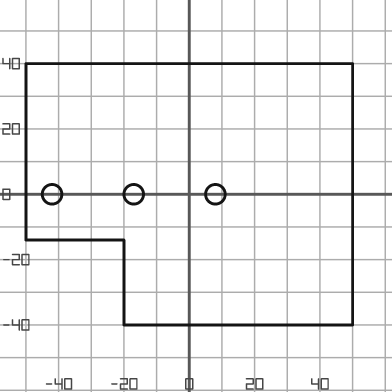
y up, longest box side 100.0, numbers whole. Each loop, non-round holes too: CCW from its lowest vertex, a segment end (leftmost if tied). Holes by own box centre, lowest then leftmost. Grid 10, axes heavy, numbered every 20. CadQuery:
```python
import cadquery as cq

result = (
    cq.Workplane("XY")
    .moveTo(-20.0, -40.0)
    .lineTo(50.0, -40.0)
    .lineTo(50.0, 40.0)
    .lineTo(-50.0, 40.0)
    .lineTo(-50.0, -14.0)
    .lineTo(-20.0, -14.0)
    .close()
    .moveTo(-42.0, 0.0)
    .circle(3.0)
    .moveTo(-17.0, 0.0)
    .circle(3.0)
    .moveTo(8.0, 0.0)
    .circle(3.0)
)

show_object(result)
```